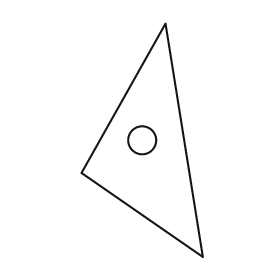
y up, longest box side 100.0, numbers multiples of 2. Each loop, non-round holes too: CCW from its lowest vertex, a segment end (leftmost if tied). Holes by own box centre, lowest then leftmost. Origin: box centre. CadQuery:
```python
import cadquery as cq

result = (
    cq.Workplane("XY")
    .moveTo(26.0, -50.0)
    .lineTo(10.0, 50.0)
    .lineTo(-26.0, -14.0)
    .close()
    .moveTo(0.0, 0.0)
    .circle(6.0)
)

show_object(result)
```